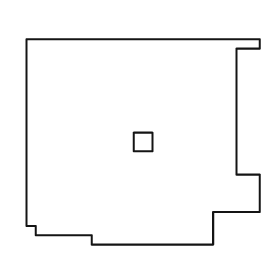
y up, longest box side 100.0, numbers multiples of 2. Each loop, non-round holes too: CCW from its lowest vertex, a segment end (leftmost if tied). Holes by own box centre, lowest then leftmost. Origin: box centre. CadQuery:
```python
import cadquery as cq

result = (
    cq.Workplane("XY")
    .moveTo(-22.0, -44.0)
    .lineTo(30.0, -44.0)
    .lineTo(30.0, -30.0)
    .lineTo(50.0, -30.0)
    .lineTo(50.0, -14.0)
    .lineTo(40.0, -14.0)
    .lineTo(40.0, 40.0)
    .lineTo(50.0, 40.0)
    .lineTo(50.0, 44.0)
    .lineTo(-50.0, 44.0)
    .lineTo(-50.0, -36.0)
    .lineTo(-46.0, -36.0)
    .lineTo(-46.0, -40.0)
    .lineTo(-22.0, -40.0)
    .close()
    .moveTo(-4.0, -4.0)
    .lineTo(4.0, -4.0)
    .lineTo(4.0, 4.0)
    .lineTo(-4.0, 4.0)
    .close()
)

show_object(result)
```